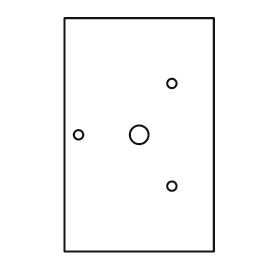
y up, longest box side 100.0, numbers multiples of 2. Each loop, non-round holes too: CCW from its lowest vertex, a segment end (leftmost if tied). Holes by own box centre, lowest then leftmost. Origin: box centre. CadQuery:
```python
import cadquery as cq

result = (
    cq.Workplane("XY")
    .moveTo(-32.0, -50.0)
    .lineTo(32.0, -50.0)
    .lineTo(32.0, 50.0)
    .lineTo(-32.0, 50.0)
    .close()
    .moveTo(14.0, -22.0)
    .circle(2.0)
    .moveTo(-26.0, 0.0)
    .circle(2.0)
    .moveTo(0.0, 0.0)
    .circle(4.0)
    .moveTo(14.0, 22.0)
    .circle(2.0)
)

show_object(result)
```